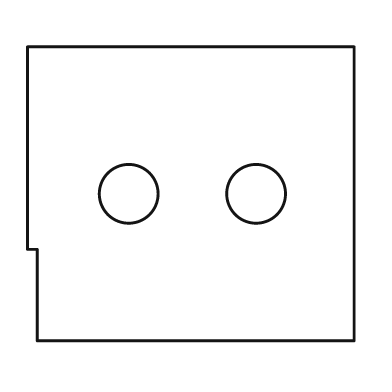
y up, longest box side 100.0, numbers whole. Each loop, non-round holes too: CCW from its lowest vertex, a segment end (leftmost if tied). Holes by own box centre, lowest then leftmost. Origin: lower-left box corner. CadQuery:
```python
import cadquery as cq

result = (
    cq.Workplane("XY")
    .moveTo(3.0, 0.0)
    .lineTo(100.0, 0.0)
    .lineTo(100.0, 90.0)
    .lineTo(0.0, 90.0)
    .lineTo(0.0, 28.0)
    .lineTo(3.0, 28.0)
    .close()
    .moveTo(31.0, 45.0)
    .circle(9.0)
    .moveTo(70.0, 45.0)
    .circle(9.0)
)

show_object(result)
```